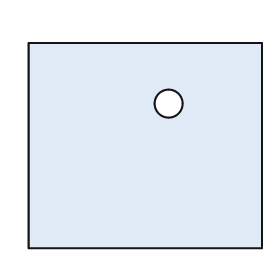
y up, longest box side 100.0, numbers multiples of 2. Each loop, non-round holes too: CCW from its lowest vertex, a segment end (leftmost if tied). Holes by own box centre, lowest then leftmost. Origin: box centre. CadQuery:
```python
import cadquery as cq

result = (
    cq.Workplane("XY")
    .moveTo(-50.0, -44.0)
    .lineTo(50.0, -44.0)
    .lineTo(50.0, 44.0)
    .lineTo(-50.0, 44.0)
    .close()
    .moveTo(10.0, 18.0)
    .circle(6.0)
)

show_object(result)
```